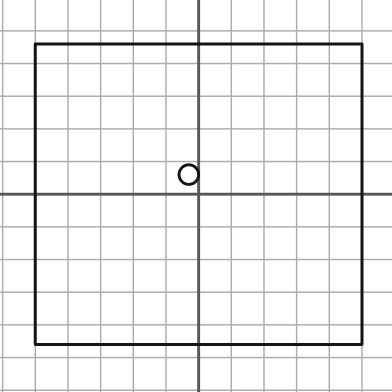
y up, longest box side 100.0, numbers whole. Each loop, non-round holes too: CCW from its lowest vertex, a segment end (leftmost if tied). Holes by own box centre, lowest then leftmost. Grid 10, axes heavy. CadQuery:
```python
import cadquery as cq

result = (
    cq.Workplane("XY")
    .moveTo(-50.0, -46.0)
    .lineTo(50.0, -46.0)
    .lineTo(50.0, 46.0)
    .lineTo(-50.0, 46.0)
    .close()
    .moveTo(-3.0, 6.0)
    .circle(3.0)
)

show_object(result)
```